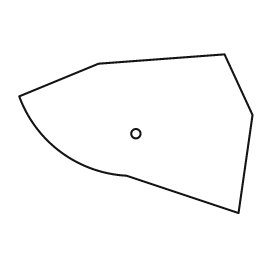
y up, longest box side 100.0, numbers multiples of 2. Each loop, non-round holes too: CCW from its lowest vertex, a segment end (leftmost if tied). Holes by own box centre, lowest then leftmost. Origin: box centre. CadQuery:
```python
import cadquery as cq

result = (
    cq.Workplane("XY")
    .moveTo(44.0, -34.0)
    .lineTo(50.0, 8.0)
    .lineTo(38.0, 34.0)
    .lineTo(-16.0, 30.0)
    .lineTo(-50.0, 16.0)
    .threePointArc((-32.0, -8.0), (-4.0, -18.0))
    .close()
    .moveTo(0.0, 0.0)
    .circle(2.0)
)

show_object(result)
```